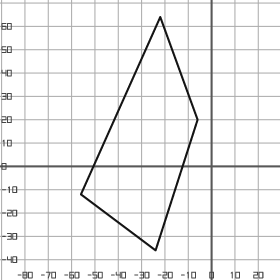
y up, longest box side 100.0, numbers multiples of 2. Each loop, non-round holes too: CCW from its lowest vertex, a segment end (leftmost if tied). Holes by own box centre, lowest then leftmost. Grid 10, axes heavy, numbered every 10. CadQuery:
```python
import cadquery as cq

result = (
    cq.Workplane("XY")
    .moveTo(-24.0, -36.0)
    .lineTo(-6.0, 20.0)
    .lineTo(-22.0, 64.0)
    .lineTo(-56.0, -12.0)
    .close()
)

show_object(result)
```